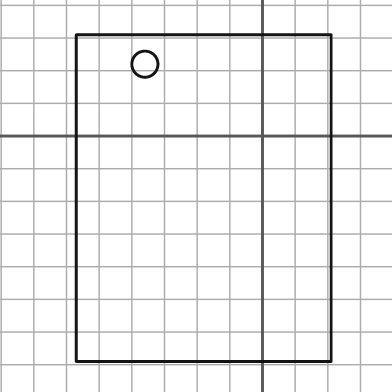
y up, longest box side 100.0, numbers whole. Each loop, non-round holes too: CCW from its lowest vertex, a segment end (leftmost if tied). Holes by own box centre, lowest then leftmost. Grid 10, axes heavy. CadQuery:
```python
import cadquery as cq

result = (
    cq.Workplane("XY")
    .moveTo(-57.0, -69.0)
    .lineTo(21.0, -69.0)
    .lineTo(21.0, 31.0)
    .lineTo(-57.0, 31.0)
    .close()
    .moveTo(-36.0, 22.0)
    .circle(4.0)
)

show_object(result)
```